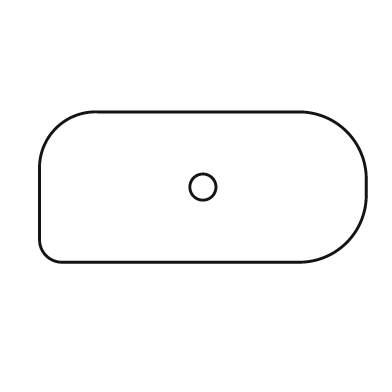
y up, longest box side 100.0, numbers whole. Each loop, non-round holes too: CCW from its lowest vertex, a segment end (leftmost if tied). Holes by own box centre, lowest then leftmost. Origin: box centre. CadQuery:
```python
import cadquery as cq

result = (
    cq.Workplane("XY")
    .moveTo(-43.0, -23.0)
    .lineTo(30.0, -23.0)
    .threePointArc((44.0, -17.0), (50.0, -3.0))
    .lineTo(50.0, 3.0)
    .threePointArc((44.0, 17.0), (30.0, 23.0))
    .lineTo(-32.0, 23.0)
    .threePointArc((-45.0, 18.0), (-50.0, 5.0))
    .lineTo(-50.0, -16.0)
    .threePointArc((-48.0, -21.0), (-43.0, -23.0))
    .close()
    .moveTo(0.0, 0.0)
    .circle(4.0)
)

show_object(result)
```